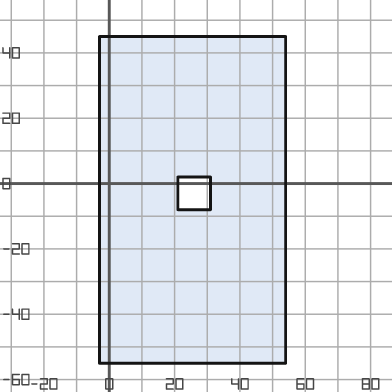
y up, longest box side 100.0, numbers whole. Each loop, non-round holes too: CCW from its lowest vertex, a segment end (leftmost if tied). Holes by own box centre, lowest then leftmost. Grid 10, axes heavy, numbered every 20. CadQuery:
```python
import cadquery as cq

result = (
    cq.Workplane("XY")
    .moveTo(-3.0, -55.0)
    .lineTo(54.0, -55.0)
    .lineTo(54.0, 45.0)
    .lineTo(-3.0, 45.0)
    .close()
    .moveTo(21.0, -8.0)
    .lineTo(31.0, -8.0)
    .lineTo(31.0, 2.0)
    .lineTo(21.0, 2.0)
    .close()
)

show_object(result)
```